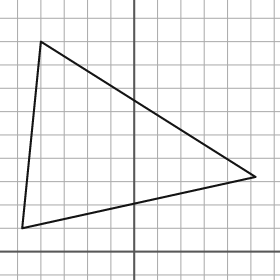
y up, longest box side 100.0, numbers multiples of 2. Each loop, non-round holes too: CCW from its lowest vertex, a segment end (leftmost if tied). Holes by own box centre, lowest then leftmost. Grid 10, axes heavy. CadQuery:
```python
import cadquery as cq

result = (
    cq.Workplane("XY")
    .moveTo(-48.0, 10.0)
    .lineTo(52.0, 32.0)
    .lineTo(-40.0, 90.0)
    .close()
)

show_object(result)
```